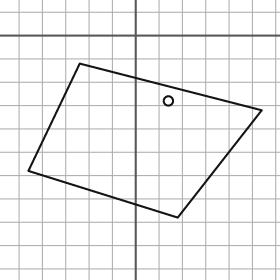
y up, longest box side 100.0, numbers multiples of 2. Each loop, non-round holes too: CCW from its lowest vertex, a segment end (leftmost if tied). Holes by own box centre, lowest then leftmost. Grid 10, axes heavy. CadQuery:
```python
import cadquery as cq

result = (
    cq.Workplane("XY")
    .moveTo(18.0, -78.0)
    .lineTo(54.0, -32.0)
    .lineTo(-24.0, -12.0)
    .lineTo(-46.0, -58.0)
    .close()
    .moveTo(14.0, -28.0)
    .circle(2.0)
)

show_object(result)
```